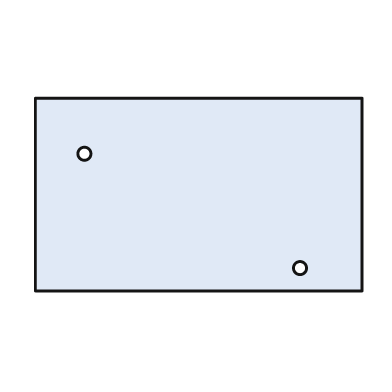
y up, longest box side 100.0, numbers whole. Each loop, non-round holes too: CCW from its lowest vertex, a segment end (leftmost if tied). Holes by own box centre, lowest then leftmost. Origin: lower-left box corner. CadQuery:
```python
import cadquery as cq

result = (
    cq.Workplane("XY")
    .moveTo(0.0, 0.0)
    .lineTo(100.0, 0.0)
    .lineTo(100.0, 59.0)
    .lineTo(0.0, 59.0)
    .close()
    .moveTo(81.0, 7.0)
    .circle(2.0)
    .moveTo(15.0, 42.0)
    .circle(2.0)
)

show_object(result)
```